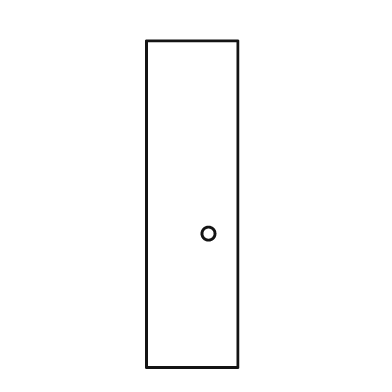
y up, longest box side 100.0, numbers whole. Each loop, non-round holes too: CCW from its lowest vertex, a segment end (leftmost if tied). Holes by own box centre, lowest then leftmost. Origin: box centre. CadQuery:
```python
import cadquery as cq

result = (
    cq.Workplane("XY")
    .moveTo(-14.0, -50.0)
    .lineTo(14.0, -50.0)
    .lineTo(14.0, 50.0)
    .lineTo(-14.0, 50.0)
    .close()
    .moveTo(5.0, -9.0)
    .circle(2.0)
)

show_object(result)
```